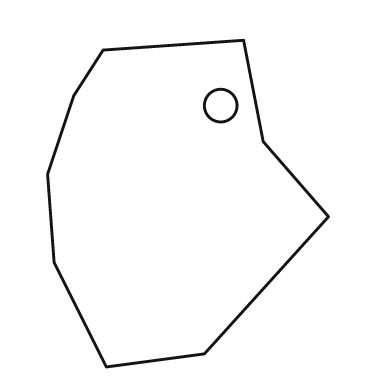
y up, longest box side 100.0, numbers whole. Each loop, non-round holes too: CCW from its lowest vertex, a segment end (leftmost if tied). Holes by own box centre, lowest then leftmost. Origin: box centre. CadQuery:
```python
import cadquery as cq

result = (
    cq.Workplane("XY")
    .moveTo(-25.0, -50.0)
    .lineTo(5.0, -46.0)
    .lineTo(43.0, -4.0)
    .lineTo(23.0, 19.0)
    .lineTo(17.0, 50.0)
    .lineTo(-26.0, 47.0)
    .lineTo(-35.0, 33.0)
    .lineTo(-43.0, 9.0)
    .lineTo(-41.0, -18.0)
    .close()
    .moveTo(10.0, 30.0)
    .circle(5.0)
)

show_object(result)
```